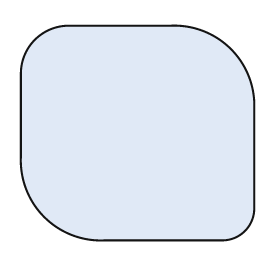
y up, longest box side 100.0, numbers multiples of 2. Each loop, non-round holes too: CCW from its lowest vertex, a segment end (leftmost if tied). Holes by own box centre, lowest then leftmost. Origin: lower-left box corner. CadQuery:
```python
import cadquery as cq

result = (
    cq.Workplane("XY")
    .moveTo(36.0, 0.0)
    .lineTo(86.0, 0.0)
    .threePointArc((96.0, 4.0), (100.0, 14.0))
    .lineTo(100.0, 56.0)
    .threePointArc((90.0, 82.0), (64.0, 92.0))
    .lineTo(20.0, 92.0)
    .threePointArc((6.0, 86.0), (0.0, 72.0))
    .lineTo(0.0, 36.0)
    .threePointArc((10.0, 10.0), (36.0, 0.0))
    .close()
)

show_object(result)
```